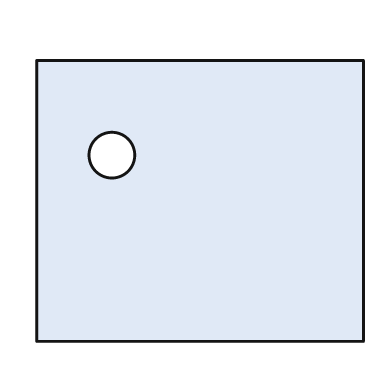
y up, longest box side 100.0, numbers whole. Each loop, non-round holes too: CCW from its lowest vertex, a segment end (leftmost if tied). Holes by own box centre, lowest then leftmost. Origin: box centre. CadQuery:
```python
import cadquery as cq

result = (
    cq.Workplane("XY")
    .moveTo(-50.0, -43.0)
    .lineTo(50.0, -43.0)
    .lineTo(50.0, 43.0)
    .lineTo(-50.0, 43.0)
    .close()
    .moveTo(-27.0, 14.0)
    .circle(7.0)
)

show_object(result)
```